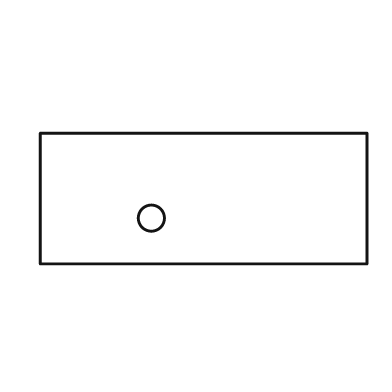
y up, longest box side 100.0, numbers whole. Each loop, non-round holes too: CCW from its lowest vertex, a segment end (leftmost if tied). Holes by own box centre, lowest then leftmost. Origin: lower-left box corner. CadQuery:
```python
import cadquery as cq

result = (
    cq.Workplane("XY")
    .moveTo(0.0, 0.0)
    .lineTo(100.0, 0.0)
    .lineTo(100.0, 40.0)
    .lineTo(0.0, 40.0)
    .close()
    .moveTo(34.0, 14.0)
    .circle(4.0)
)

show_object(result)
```